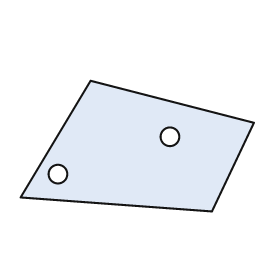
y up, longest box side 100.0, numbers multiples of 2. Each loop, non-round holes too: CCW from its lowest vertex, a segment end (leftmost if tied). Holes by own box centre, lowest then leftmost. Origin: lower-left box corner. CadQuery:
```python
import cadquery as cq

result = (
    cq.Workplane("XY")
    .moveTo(82.0, 0.0)
    .lineTo(100.0, 38.0)
    .lineTo(30.0, 56.0)
    .lineTo(0.0, 6.0)
    .close()
    .moveTo(16.0, 16.0)
    .circle(4.0)
    .moveTo(64.0, 32.0)
    .circle(4.0)
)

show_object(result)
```